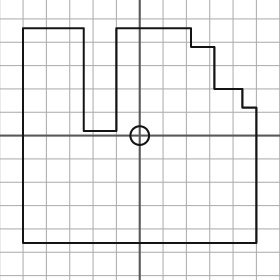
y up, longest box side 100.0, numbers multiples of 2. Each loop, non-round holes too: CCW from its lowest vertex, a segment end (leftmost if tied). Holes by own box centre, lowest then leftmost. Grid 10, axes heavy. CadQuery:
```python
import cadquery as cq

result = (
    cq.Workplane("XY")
    .moveTo(-50.0, -46.0)
    .lineTo(50.0, -46.0)
    .lineTo(50.0, 12.0)
    .lineTo(44.0, 12.0)
    .lineTo(44.0, 20.0)
    .lineTo(32.0, 20.0)
    .lineTo(32.0, 38.0)
    .lineTo(22.0, 38.0)
    .lineTo(22.0, 46.0)
    .lineTo(-10.0, 46.0)
    .lineTo(-10.0, 2.0)
    .lineTo(-24.0, 2.0)
    .lineTo(-24.0, 46.0)
    .lineTo(-50.0, 46.0)
    .close()
    .moveTo(0.0, 0.0)
    .circle(4.0)
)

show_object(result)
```